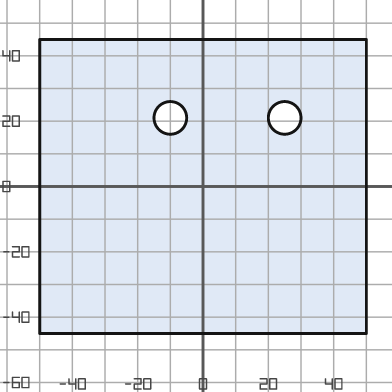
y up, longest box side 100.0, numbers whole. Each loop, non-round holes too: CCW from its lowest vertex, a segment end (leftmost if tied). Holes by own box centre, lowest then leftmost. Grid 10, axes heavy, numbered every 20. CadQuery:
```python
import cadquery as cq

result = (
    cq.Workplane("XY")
    .moveTo(-50.0, -45.0)
    .lineTo(50.0, -45.0)
    .lineTo(50.0, 45.0)
    .lineTo(-50.0, 45.0)
    .close()
    .moveTo(-10.0, 21.0)
    .circle(5.0)
    .moveTo(25.0, 21.0)
    .circle(5.0)
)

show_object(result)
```